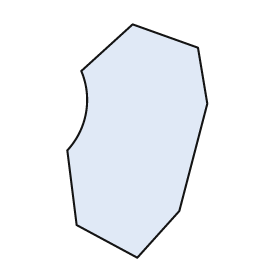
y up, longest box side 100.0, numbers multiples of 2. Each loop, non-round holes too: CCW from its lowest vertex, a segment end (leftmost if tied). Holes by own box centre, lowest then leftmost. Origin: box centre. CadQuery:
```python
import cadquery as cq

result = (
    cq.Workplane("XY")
    .moveTo(0.0, -50.0)
    .lineTo(18.0, -30.0)
    .lineTo(30.0, 16.0)
    .lineTo(26.0, 40.0)
    .lineTo(-2.0, 50.0)
    .lineTo(-24.0, 30.0)
    .threePointArc((-22.0, 12.0), (-30.0, -4.0))
    .lineTo(-26.0, -36.0)
    .close()
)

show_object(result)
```